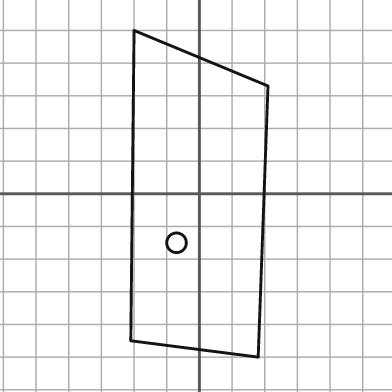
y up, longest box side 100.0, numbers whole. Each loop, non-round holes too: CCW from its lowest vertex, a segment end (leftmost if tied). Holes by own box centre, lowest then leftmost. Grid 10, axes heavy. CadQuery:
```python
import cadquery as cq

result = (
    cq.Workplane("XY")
    .moveTo(18.0, -50.0)
    .lineTo(21.0, 33.0)
    .lineTo(-20.0, 50.0)
    .lineTo(-21.0, -45.0)
    .close()
    .moveTo(-7.0, -15.0)
    .circle(3.0)
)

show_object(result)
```